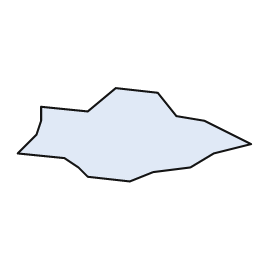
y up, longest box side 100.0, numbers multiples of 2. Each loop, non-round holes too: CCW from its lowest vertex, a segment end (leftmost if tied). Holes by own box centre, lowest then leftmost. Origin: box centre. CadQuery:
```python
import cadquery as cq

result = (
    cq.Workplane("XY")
    .moveTo(-2.0, -20.0)
    .lineTo(8.0, -16.0)
    .lineTo(24.0, -14.0)
    .lineTo(34.0, -8.0)
    .lineTo(50.0, -4.0)
    .lineTo(30.0, 6.0)
    .lineTo(18.0, 8.0)
    .lineTo(10.0, 18.0)
    .lineTo(-8.0, 20.0)
    .lineTo(-20.0, 10.0)
    .lineTo(-40.0, 12.0)
    .lineTo(-40.0, 6.0)
    .lineTo(-42.0, 0.0)
    .lineTo(-50.0, -8.0)
    .lineTo(-30.0, -10.0)
    .lineTo(-24.0, -14.0)
    .lineTo(-20.0, -18.0)
    .close()
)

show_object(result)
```